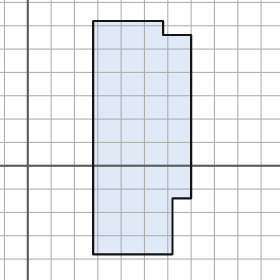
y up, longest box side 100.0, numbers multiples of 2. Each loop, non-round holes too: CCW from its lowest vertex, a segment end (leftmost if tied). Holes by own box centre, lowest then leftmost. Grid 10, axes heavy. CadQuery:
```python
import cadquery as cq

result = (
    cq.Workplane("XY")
    .moveTo(28.0, -38.0)
    .lineTo(62.0, -38.0)
    .lineTo(62.0, -14.0)
    .lineTo(70.0, -14.0)
    .lineTo(70.0, 56.0)
    .lineTo(58.0, 56.0)
    .lineTo(58.0, 62.0)
    .lineTo(28.0, 62.0)
    .close()
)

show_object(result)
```